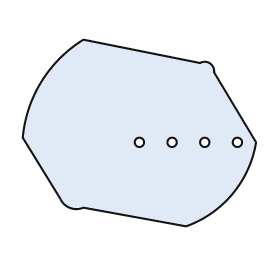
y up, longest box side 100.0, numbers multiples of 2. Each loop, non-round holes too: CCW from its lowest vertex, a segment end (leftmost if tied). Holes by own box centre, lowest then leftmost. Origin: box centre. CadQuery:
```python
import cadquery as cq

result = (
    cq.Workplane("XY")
    .moveTo(20.0, -40.0)
    .threePointArc((40.0, -26.0), (50.0, -4.0))
    .lineTo(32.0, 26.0)
    .threePointArc((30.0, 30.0), (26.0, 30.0))
    .lineTo(-24.0, 40.0)
    .threePointArc((-42.0, 22.0), (-50.0, -2.0))
    .lineTo(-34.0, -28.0)
    .threePointArc((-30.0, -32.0), (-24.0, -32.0))
    .close()
    .moveTo(0.0, -4.0)
    .circle(2.0)
    .moveTo(14.0, -4.0)
    .circle(2.0)
    .moveTo(28.0, -4.0)
    .circle(2.0)
    .moveTo(42.0, -4.0)
    .circle(2.0)
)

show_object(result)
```